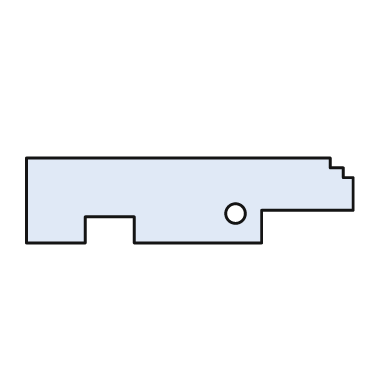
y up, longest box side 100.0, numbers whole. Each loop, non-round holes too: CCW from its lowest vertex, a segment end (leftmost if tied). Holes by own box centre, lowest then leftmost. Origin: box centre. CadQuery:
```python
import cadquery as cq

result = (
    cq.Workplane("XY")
    .moveTo(-50.0, -13.0)
    .lineTo(-32.0, -13.0)
    .lineTo(-32.0, -5.0)
    .lineTo(-17.0, -5.0)
    .lineTo(-17.0, -13.0)
    .lineTo(22.0, -13.0)
    .lineTo(22.0, -3.0)
    .lineTo(50.0, -3.0)
    .lineTo(50.0, 7.0)
    .lineTo(47.0, 7.0)
    .lineTo(47.0, 10.0)
    .lineTo(43.0, 10.0)
    .lineTo(43.0, 13.0)
    .lineTo(-50.0, 13.0)
    .close()
    .moveTo(14.0, -4.0)
    .circle(3.0)
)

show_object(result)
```